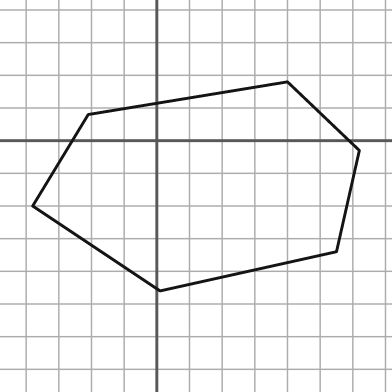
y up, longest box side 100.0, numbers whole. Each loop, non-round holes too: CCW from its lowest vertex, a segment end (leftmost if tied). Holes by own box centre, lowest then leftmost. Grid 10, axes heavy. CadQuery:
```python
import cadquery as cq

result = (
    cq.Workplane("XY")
    .moveTo(1.0, -46.0)
    .lineTo(55.0, -34.0)
    .lineTo(62.0, -3.0)
    .lineTo(40.0, 18.0)
    .lineTo(-21.0, 8.0)
    .lineTo(-38.0, -20.0)
    .close()
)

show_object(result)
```